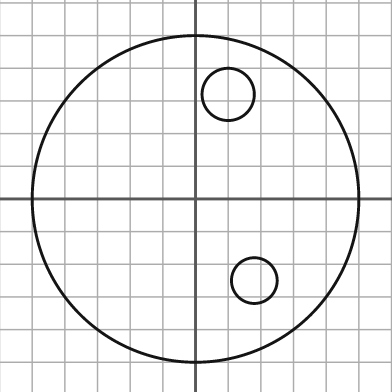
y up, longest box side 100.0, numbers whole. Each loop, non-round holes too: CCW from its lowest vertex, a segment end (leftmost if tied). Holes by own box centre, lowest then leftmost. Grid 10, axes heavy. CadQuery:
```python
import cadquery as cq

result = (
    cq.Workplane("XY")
    .moveTo(0.0, 0.0)
    .circle(50.0)
    .moveTo(18.0, -25.0)
    .circle(7.0)
    .moveTo(10.0, 32.0)
    .circle(8.0)
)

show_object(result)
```